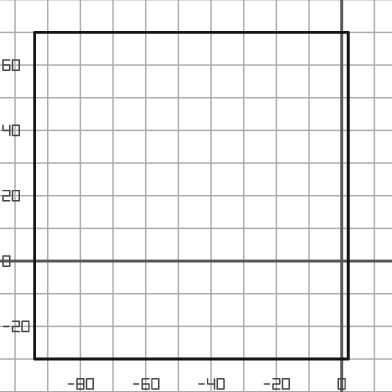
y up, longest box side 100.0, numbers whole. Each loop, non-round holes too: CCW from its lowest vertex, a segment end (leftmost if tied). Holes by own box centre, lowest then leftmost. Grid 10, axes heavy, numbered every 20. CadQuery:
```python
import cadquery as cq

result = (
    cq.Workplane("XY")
    .moveTo(-94.0, -30.0)
    .lineTo(2.0, -30.0)
    .lineTo(2.0, 70.0)
    .lineTo(-94.0, 70.0)
    .close()
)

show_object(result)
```